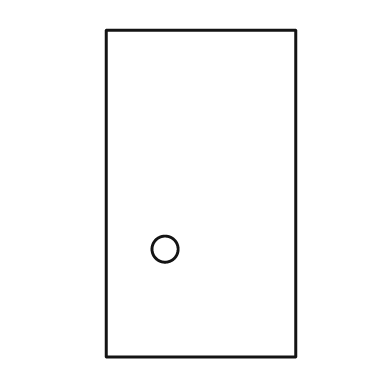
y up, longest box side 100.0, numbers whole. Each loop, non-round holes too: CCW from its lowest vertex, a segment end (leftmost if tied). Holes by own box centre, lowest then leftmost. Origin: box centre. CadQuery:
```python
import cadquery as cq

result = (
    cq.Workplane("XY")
    .moveTo(-29.0, -50.0)
    .lineTo(29.0, -50.0)
    .lineTo(29.0, 50.0)
    .lineTo(-29.0, 50.0)
    .close()
    .moveTo(-11.0, -17.0)
    .circle(4.0)
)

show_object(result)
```